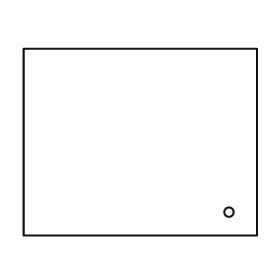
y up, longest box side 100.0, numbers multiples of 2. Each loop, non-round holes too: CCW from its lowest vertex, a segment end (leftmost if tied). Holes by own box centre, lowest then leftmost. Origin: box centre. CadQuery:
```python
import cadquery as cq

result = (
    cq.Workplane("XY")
    .moveTo(-50.0, -40.0)
    .lineTo(50.0, -40.0)
    .lineTo(50.0, 40.0)
    .lineTo(-50.0, 40.0)
    .close()
    .moveTo(38.0, -30.0)
    .circle(2.0)
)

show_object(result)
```